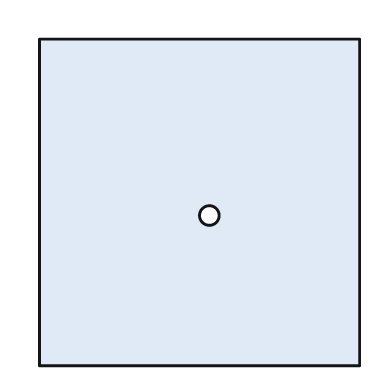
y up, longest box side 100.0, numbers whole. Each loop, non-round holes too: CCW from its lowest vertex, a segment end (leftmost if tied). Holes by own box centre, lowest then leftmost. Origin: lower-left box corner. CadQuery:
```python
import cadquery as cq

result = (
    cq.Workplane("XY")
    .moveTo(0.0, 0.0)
    .lineTo(98.0, 0.0)
    .lineTo(98.0, 100.0)
    .lineTo(0.0, 100.0)
    .close()
    .moveTo(52.0, 46.0)
    .circle(3.0)
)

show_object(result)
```